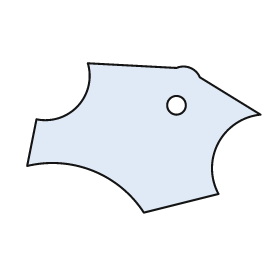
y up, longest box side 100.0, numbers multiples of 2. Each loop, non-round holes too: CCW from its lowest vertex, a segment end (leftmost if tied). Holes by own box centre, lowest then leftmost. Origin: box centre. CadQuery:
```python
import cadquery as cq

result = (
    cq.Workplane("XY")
    .moveTo(0.0, -32.0)
    .lineTo(32.0, -24.0)
    .threePointArc((32.0, -2.0), (50.0, 10.0))
    .lineTo(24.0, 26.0)
    .threePointArc((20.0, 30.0), (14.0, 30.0))
    .lineTo(-24.0, 32.0)
    .threePointArc((-28.0, 14.0), (-46.0, 8.0))
    .lineTo(-50.0, -12.0)
    .threePointArc((-22.0, -14.0), (0.0, -32.0))
    .close()
    .moveTo(14.0, 14.0)
    .circle(4.0)
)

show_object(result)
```